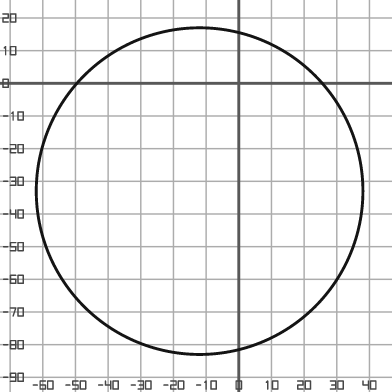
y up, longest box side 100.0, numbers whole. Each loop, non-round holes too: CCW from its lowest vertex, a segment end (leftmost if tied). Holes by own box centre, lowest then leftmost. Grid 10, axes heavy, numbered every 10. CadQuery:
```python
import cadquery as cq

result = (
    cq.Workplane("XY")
    .moveTo(-12.0, -33.0)
    .circle(50.0)
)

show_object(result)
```